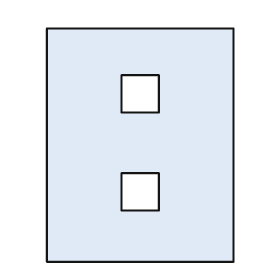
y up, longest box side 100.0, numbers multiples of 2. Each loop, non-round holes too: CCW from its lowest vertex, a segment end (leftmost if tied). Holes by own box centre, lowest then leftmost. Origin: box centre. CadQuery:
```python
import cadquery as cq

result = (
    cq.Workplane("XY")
    .moveTo(-40.0, -50.0)
    .lineTo(40.0, -50.0)
    .lineTo(40.0, 50.0)
    .lineTo(-40.0, 50.0)
    .close()
    .moveTo(-8.0, -28.0)
    .lineTo(8.0, -28.0)
    .lineTo(8.0, -12.0)
    .lineTo(-8.0, -12.0)
    .close()
    .moveTo(-8.0, 14.0)
    .lineTo(8.0, 14.0)
    .lineTo(8.0, 30.0)
    .lineTo(-8.0, 30.0)
    .close()
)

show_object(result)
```